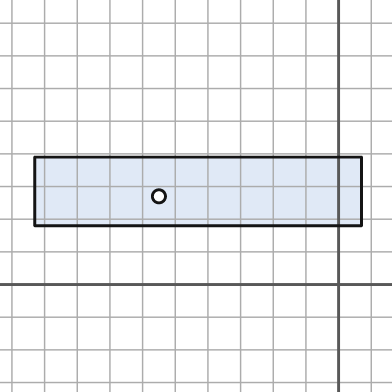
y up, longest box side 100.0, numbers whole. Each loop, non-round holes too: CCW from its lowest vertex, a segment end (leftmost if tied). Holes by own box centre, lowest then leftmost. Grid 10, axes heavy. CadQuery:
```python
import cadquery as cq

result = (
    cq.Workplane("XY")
    .moveTo(-93.0, 18.0)
    .lineTo(7.0, 18.0)
    .lineTo(7.0, 39.0)
    .lineTo(-93.0, 39.0)
    .close()
    .moveTo(-55.0, 27.0)
    .circle(2.0)
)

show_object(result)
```